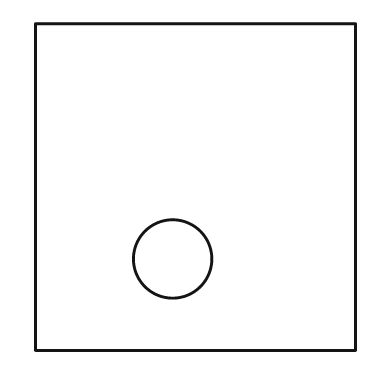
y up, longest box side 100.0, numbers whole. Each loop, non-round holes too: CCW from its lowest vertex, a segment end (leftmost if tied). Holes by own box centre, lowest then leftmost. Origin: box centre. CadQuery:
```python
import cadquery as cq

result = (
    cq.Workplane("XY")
    .moveTo(-49.0, -50.0)
    .lineTo(49.0, -50.0)
    .lineTo(49.0, 50.0)
    .lineTo(-49.0, 50.0)
    .close()
    .moveTo(-7.0, -22.0)
    .circle(12.0)
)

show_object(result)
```